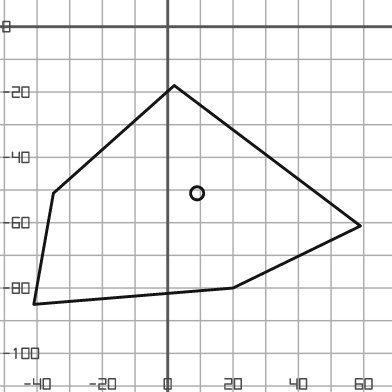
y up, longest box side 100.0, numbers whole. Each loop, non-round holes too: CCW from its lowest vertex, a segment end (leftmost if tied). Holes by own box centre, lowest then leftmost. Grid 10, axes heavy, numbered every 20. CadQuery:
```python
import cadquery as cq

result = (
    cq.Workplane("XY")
    .moveTo(-41.0, -85.0)
    .lineTo(20.0, -80.0)
    .lineTo(59.0, -61.0)
    .lineTo(2.0, -18.0)
    .lineTo(-35.0, -51.0)
    .close()
    .moveTo(9.0, -51.0)
    .circle(2.0)
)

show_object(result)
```